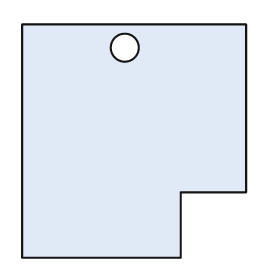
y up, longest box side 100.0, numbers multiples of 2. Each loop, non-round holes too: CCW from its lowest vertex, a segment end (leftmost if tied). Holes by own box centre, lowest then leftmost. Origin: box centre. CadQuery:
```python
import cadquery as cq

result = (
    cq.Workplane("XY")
    .moveTo(-48.0, -50.0)
    .lineTo(20.0, -50.0)
    .lineTo(20.0, -22.0)
    .lineTo(48.0, -22.0)
    .lineTo(48.0, 50.0)
    .lineTo(-48.0, 50.0)
    .close()
    .moveTo(-4.0, 40.0)
    .circle(6.0)
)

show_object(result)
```